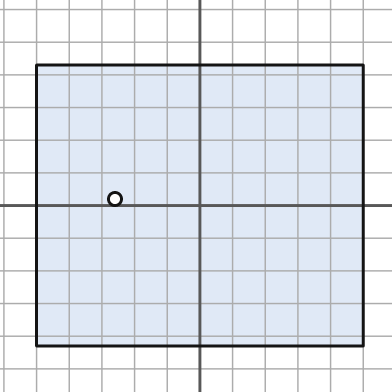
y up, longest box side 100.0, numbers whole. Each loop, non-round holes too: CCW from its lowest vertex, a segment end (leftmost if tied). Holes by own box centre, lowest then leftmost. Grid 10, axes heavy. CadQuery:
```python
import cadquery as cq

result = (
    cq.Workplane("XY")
    .moveTo(-50.0, -43.0)
    .lineTo(50.0, -43.0)
    .lineTo(50.0, 43.0)
    .lineTo(-50.0, 43.0)
    .close()
    .moveTo(-26.0, 2.0)
    .circle(2.0)
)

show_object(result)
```